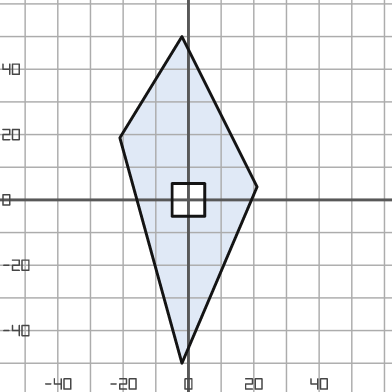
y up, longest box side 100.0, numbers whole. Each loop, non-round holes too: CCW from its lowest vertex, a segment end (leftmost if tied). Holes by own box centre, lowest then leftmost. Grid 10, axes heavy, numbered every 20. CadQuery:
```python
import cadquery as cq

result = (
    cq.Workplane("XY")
    .moveTo(-2.0, -50.0)
    .lineTo(21.0, 4.0)
    .lineTo(-2.0, 50.0)
    .lineTo(-21.0, 19.0)
    .close()
    .moveTo(-5.0, -5.0)
    .lineTo(5.0, -5.0)
    .lineTo(5.0, 5.0)
    .lineTo(-5.0, 5.0)
    .close()
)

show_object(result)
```